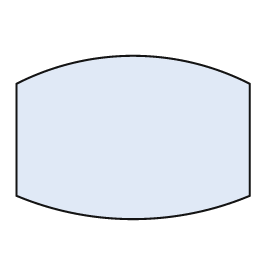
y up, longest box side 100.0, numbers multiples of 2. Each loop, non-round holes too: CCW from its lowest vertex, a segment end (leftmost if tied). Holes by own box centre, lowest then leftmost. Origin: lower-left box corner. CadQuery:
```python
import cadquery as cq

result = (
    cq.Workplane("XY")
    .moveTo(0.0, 10.0)
    .threePointArc((50.0, 0.0), (100.0, 10.0))
    .lineTo(100.0, 58.0)
    .threePointArc((50.0, 70.0), (0.0, 58.0))
    .close()
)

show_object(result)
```